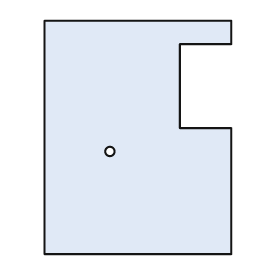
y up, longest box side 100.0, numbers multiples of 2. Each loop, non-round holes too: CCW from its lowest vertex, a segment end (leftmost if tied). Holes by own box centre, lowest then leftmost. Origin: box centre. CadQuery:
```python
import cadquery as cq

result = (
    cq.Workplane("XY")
    .moveTo(-40.0, -50.0)
    .lineTo(40.0, -50.0)
    .lineTo(40.0, 4.0)
    .lineTo(18.0, 4.0)
    .lineTo(18.0, 40.0)
    .lineTo(40.0, 40.0)
    .lineTo(40.0, 50.0)
    .lineTo(-40.0, 50.0)
    .close()
    .moveTo(-12.0, -6.0)
    .circle(2.0)
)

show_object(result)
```